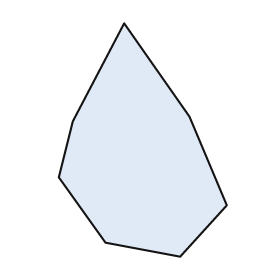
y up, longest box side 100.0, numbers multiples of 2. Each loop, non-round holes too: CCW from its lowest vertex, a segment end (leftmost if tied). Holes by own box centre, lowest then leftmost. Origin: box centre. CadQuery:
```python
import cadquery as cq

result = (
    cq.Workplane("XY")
    .moveTo(16.0, -50.0)
    .lineTo(36.0, -28.0)
    .lineTo(20.0, 10.0)
    .lineTo(-8.0, 50.0)
    .lineTo(-30.0, 8.0)
    .lineTo(-36.0, -16.0)
    .lineTo(-16.0, -44.0)
    .close()
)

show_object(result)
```